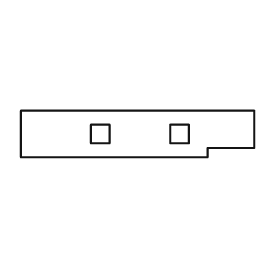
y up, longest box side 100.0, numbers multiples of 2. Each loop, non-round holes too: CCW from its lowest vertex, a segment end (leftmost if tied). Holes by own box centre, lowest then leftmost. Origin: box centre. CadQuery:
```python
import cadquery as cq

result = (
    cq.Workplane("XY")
    .moveTo(-50.0, -10.0)
    .lineTo(30.0, -10.0)
    .lineTo(30.0, -6.0)
    .lineTo(50.0, -6.0)
    .lineTo(50.0, 10.0)
    .lineTo(-50.0, 10.0)
    .close()
    .moveTo(-20.0, -4.0)
    .lineTo(-12.0, -4.0)
    .lineTo(-12.0, 4.0)
    .lineTo(-20.0, 4.0)
    .close()
    .moveTo(14.0, -4.0)
    .lineTo(22.0, -4.0)
    .lineTo(22.0, 4.0)
    .lineTo(14.0, 4.0)
    .close()
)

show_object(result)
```